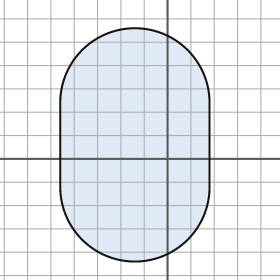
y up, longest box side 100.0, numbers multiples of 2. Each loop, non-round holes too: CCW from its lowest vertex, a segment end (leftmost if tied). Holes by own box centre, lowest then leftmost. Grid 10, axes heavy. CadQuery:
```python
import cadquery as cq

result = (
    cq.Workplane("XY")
    .moveTo(-46.0, -12.0)
    .threePointArc((-14.0, -44.0), (18.0, -12.0))
    .lineTo(18.0, 24.0)
    .threePointArc((-14.0, 56.0), (-46.0, 24.0))
    .close()
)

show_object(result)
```